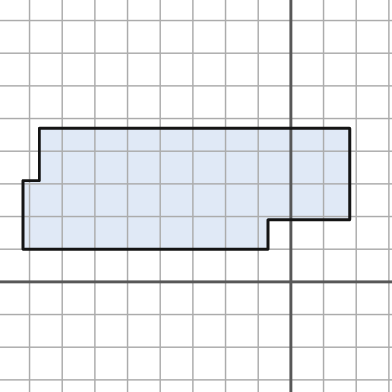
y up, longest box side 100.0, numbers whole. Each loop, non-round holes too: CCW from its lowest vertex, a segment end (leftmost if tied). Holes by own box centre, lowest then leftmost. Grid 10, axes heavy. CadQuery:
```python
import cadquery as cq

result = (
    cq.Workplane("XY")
    .moveTo(-82.0, 10.0)
    .lineTo(-7.0, 10.0)
    .lineTo(-7.0, 19.0)
    .lineTo(18.0, 19.0)
    .lineTo(18.0, 47.0)
    .lineTo(-77.0, 47.0)
    .lineTo(-77.0, 31.0)
    .lineTo(-82.0, 31.0)
    .close()
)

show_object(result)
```